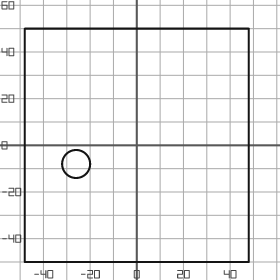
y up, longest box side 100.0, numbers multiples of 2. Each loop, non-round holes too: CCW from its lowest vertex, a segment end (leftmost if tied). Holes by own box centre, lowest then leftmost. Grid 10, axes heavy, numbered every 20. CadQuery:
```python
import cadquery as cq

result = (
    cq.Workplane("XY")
    .moveTo(-48.0, -50.0)
    .lineTo(48.0, -50.0)
    .lineTo(48.0, 50.0)
    .lineTo(-48.0, 50.0)
    .close()
    .moveTo(-26.0, -8.0)
    .circle(6.0)
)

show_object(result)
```